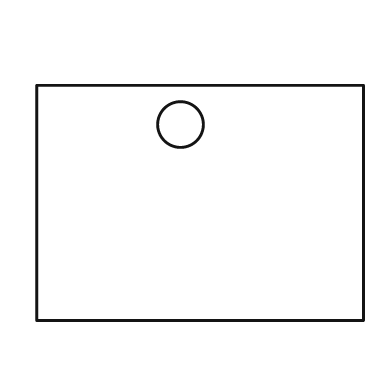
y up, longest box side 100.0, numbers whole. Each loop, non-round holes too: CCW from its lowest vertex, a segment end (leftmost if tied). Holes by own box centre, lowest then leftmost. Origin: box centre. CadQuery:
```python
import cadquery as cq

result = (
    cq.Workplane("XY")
    .moveTo(-50.0, -36.0)
    .lineTo(50.0, -36.0)
    .lineTo(50.0, 36.0)
    .lineTo(-50.0, 36.0)
    .close()
    .moveTo(-6.0, 24.0)
    .circle(7.0)
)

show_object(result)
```